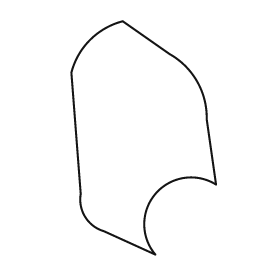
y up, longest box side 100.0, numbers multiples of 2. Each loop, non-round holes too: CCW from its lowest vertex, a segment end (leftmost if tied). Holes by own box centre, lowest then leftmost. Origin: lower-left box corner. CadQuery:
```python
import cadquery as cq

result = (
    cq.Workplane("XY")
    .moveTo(36.0, 0.0)
    .threePointArc((36.0, 26.0), (62.0, 30.0))
    .lineTo(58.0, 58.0)
    .threePointArc((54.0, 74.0), (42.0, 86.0))
    .lineTo(22.0, 100.0)
    .threePointArc((8.0, 92.0), (0.0, 78.0))
    .lineTo(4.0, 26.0)
    .threePointArc((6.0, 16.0), (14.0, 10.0))
    .close()
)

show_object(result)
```